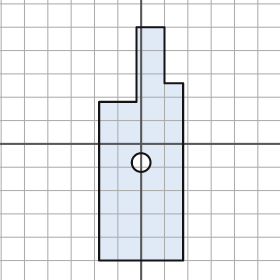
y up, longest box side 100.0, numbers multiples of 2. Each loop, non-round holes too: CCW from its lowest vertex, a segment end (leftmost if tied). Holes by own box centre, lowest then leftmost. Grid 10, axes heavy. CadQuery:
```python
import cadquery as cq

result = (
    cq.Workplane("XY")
    .moveTo(-18.0, -50.0)
    .lineTo(18.0, -50.0)
    .lineTo(18.0, 26.0)
    .lineTo(10.0, 26.0)
    .lineTo(10.0, 50.0)
    .lineTo(-2.0, 50.0)
    .lineTo(-2.0, 18.0)
    .lineTo(-18.0, 18.0)
    .close()
    .moveTo(0.0, -8.0)
    .circle(4.0)
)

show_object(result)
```